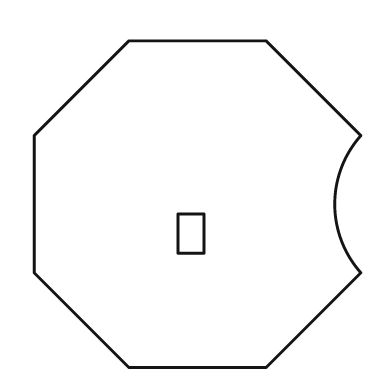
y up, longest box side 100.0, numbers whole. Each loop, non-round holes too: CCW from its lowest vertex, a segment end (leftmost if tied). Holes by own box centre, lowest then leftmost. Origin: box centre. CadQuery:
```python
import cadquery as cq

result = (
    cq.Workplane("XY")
    .moveTo(-21.0, -50.0)
    .lineTo(21.0, -50.0)
    .lineTo(50.0, -21.0)
    .threePointArc((42.0, 0.0), (50.0, 21.0))
    .lineTo(21.0, 50.0)
    .lineTo(-21.0, 50.0)
    .lineTo(-50.0, 21.0)
    .lineTo(-50.0, -21.0)
    .close()
    .moveTo(-6.0, -15.0)
    .lineTo(2.0, -15.0)
    .lineTo(2.0, -3.0)
    .lineTo(-6.0, -3.0)
    .close()
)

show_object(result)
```